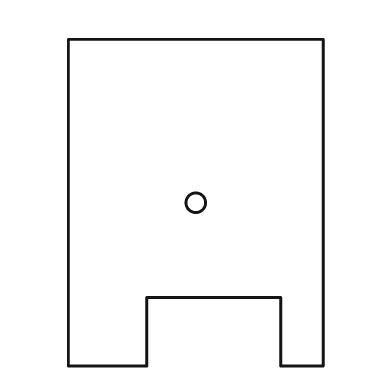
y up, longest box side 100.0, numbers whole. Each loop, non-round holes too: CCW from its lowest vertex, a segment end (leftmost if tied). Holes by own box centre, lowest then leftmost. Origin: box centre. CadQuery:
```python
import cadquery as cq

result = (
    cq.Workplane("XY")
    .moveTo(-39.0, -50.0)
    .lineTo(-15.0, -50.0)
    .lineTo(-15.0, -29.0)
    .lineTo(26.0, -29.0)
    .lineTo(26.0, -50.0)
    .lineTo(39.0, -50.0)
    .lineTo(39.0, 50.0)
    .lineTo(-39.0, 50.0)
    .close()
    .moveTo(0.0, 0.0)
    .circle(3.0)
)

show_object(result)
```